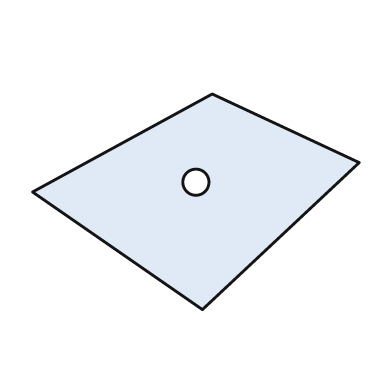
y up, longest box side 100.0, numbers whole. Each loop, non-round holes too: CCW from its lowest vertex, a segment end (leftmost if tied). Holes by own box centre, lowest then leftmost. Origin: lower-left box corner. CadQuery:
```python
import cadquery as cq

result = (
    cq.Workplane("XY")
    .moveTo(52.0, 0.0)
    .lineTo(100.0, 45.0)
    .lineTo(55.0, 66.0)
    .lineTo(0.0, 36.0)
    .close()
    .moveTo(50.0, 39.0)
    .circle(4.0)
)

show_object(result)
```